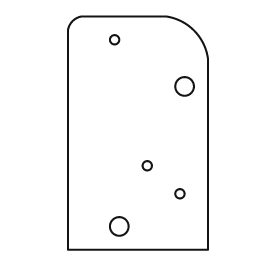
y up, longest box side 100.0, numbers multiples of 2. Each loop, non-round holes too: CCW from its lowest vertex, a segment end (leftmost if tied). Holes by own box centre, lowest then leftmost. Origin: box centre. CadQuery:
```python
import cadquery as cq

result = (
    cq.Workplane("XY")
    .moveTo(-30.0, -50.0)
    .lineTo(30.0, -50.0)
    .lineTo(30.0, 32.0)
    .threePointArc((24.0, 44.0), (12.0, 50.0))
    .lineTo(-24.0, 50.0)
    .threePointArc((-28.0, 48.0), (-30.0, 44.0))
    .close()
    .moveTo(-8.0, -40.0)
    .circle(4.0)
    .moveTo(18.0, -26.0)
    .circle(2.0)
    .moveTo(4.0, -14.0)
    .circle(2.0)
    .moveTo(20.0, 20.0)
    .circle(4.0)
    .moveTo(-10.0, 40.0)
    .circle(2.0)
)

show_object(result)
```